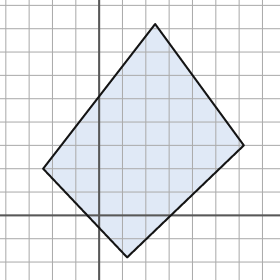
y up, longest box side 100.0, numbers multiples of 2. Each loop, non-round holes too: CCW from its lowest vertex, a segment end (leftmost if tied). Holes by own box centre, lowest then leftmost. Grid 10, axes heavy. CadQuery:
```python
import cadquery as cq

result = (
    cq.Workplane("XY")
    .moveTo(12.0, -18.0)
    .lineTo(62.0, 30.0)
    .lineTo(24.0, 82.0)
    .lineTo(-24.0, 20.0)
    .close()
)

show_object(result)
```